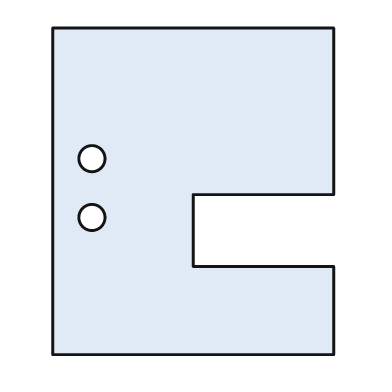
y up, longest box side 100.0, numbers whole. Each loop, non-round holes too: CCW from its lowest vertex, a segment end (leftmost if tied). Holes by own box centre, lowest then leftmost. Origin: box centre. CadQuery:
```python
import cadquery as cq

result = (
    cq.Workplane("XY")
    .moveTo(-43.0, -50.0)
    .lineTo(43.0, -50.0)
    .lineTo(43.0, -23.0)
    .lineTo(0.0, -23.0)
    .lineTo(0.0, -1.0)
    .lineTo(43.0, -1.0)
    .lineTo(43.0, 50.0)
    .lineTo(-43.0, 50.0)
    .close()
    .moveTo(-31.0, -8.0)
    .circle(4.0)
    .moveTo(-31.0, 10.0)
    .circle(4.0)
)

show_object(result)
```